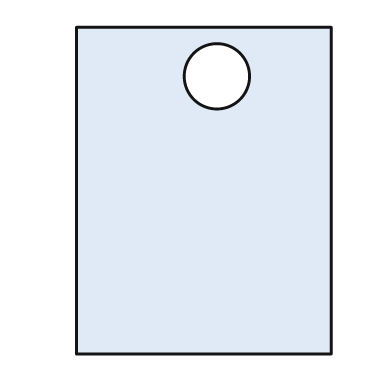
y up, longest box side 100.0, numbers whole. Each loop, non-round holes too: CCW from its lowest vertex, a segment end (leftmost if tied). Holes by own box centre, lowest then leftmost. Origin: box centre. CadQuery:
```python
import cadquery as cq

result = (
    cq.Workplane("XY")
    .moveTo(-39.0, -50.0)
    .lineTo(39.0, -50.0)
    .lineTo(39.0, 50.0)
    .lineTo(-39.0, 50.0)
    .close()
    .moveTo(4.0, 35.0)
    .circle(10.0)
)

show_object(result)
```